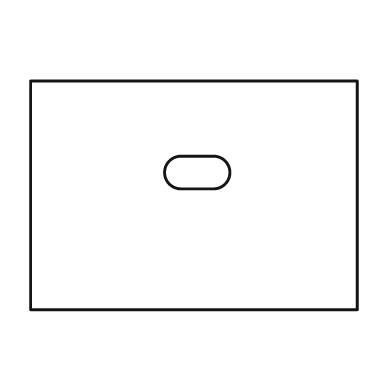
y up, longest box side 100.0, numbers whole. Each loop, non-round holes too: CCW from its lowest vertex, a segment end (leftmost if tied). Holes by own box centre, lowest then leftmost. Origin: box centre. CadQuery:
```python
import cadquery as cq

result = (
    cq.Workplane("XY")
    .moveTo(-50.0, -35.0)
    .lineTo(50.0, -35.0)
    .lineTo(50.0, 35.0)
    .lineTo(-50.0, 35.0)
    .close()
    .moveTo(-4.0, 2.0)
    .lineTo(6.0, 2.0)
    .threePointArc((11.0, 7.0), (6.0, 12.0))
    .lineTo(-4.0, 12.0)
    .threePointArc((-9.0, 7.0), (-4.0, 2.0))
    .close()
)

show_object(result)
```